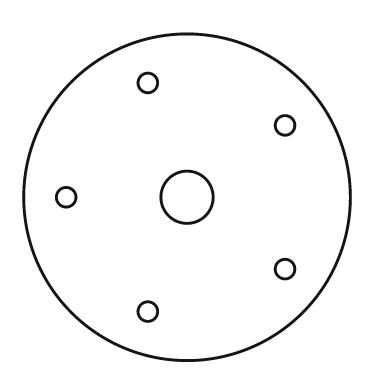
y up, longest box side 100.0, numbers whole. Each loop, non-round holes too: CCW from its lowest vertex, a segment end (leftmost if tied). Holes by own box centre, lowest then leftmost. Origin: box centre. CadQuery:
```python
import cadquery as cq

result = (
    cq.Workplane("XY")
    .moveTo(0.0, 0.0)
    .circle(50.0)
    .moveTo(-12.0, -35.0)
    .circle(3.0)
    .moveTo(30.0, -22.0)
    .circle(3.0)
    .moveTo(-37.0, 0.0)
    .circle(3.0)
    .moveTo(0.0, 0.0)
    .circle(8.0)
    .moveTo(30.0, 22.0)
    .circle(3.0)
    .moveTo(-12.0, 35.0)
    .circle(3.0)
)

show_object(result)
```